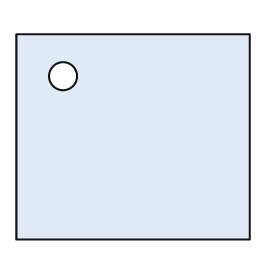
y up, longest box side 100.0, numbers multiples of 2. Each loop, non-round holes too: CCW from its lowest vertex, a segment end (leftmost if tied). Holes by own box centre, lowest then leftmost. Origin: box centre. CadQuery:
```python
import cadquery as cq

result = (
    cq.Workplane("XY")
    .moveTo(-50.0, -44.0)
    .lineTo(50.0, -44.0)
    .lineTo(50.0, 44.0)
    .lineTo(-50.0, 44.0)
    .close()
    .moveTo(-30.0, 26.0)
    .circle(6.0)
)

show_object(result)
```